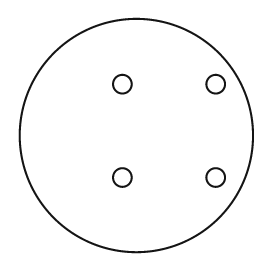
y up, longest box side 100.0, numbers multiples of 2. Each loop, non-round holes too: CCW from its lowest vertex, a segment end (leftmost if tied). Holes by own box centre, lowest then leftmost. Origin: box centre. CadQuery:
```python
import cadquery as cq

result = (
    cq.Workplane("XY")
    .moveTo(0.0, 0.0)
    .circle(50.0)
    .moveTo(-6.0, -18.0)
    .circle(4.0)
    .moveTo(34.0, -18.0)
    .circle(4.0)
    .moveTo(-6.0, 22.0)
    .circle(4.0)
    .moveTo(34.0, 22.0)
    .circle(4.0)
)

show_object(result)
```